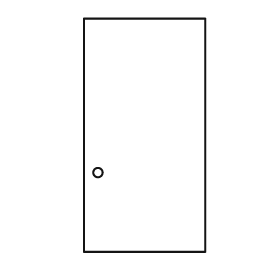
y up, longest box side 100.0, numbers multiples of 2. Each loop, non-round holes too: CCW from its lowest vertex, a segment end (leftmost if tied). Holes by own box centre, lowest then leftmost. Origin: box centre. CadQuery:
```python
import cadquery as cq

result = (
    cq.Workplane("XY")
    .moveTo(-26.0, -50.0)
    .lineTo(26.0, -50.0)
    .lineTo(26.0, 50.0)
    .lineTo(-26.0, 50.0)
    .close()
    .moveTo(-20.0, -16.0)
    .circle(2.0)
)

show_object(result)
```